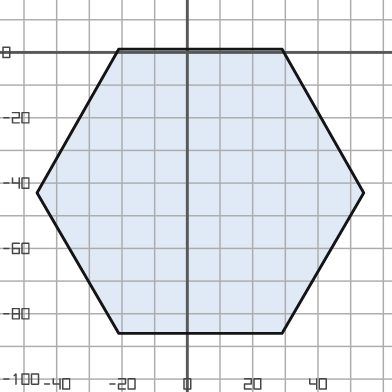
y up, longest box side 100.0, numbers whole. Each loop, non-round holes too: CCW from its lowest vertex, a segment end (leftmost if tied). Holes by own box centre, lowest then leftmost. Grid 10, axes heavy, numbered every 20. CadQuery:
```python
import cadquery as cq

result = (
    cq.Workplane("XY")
    .moveTo(-21.0, -86.0)
    .lineTo(29.0, -86.0)
    .lineTo(54.0, -43.0)
    .lineTo(29.0, 1.0)
    .lineTo(-21.0, 1.0)
    .lineTo(-46.0, -43.0)
    .close()
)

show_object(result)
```